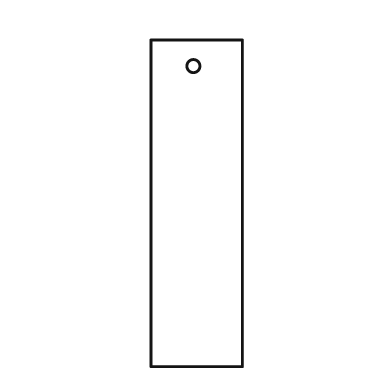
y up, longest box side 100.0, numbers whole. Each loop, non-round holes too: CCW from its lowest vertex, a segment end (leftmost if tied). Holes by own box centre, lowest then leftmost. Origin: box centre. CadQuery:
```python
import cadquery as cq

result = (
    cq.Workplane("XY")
    .moveTo(-14.0, -50.0)
    .lineTo(14.0, -50.0)
    .lineTo(14.0, 50.0)
    .lineTo(-14.0, 50.0)
    .close()
    .moveTo(-1.0, 42.0)
    .circle(2.0)
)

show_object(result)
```